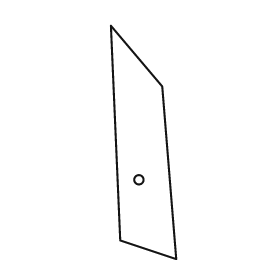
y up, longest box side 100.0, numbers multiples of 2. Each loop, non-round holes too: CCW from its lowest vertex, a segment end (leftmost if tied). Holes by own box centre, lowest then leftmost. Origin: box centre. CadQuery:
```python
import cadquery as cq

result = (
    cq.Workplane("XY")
    .moveTo(14.0, -50.0)
    .lineTo(8.0, 24.0)
    .lineTo(-14.0, 50.0)
    .lineTo(-10.0, -42.0)
    .close()
    .moveTo(-2.0, -16.0)
    .circle(2.0)
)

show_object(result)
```